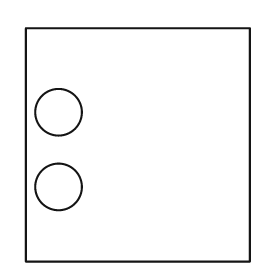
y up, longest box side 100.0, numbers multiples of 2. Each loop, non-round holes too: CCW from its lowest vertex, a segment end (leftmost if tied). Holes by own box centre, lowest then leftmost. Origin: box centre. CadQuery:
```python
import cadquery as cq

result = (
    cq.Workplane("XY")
    .moveTo(-48.0, -50.0)
    .lineTo(48.0, -50.0)
    .lineTo(48.0, 50.0)
    .lineTo(-48.0, 50.0)
    .close()
    .moveTo(-34.0, -18.0)
    .circle(10.0)
    .moveTo(-34.0, 14.0)
    .circle(10.0)
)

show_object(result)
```